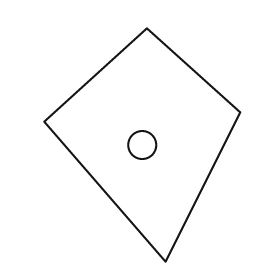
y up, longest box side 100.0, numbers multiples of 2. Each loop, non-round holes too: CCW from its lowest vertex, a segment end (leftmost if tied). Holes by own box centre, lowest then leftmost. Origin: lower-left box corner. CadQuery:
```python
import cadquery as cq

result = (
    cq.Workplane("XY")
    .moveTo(52.0, 0.0)
    .lineTo(84.0, 64.0)
    .lineTo(44.0, 100.0)
    .lineTo(0.0, 60.0)
    .close()
    .moveTo(42.0, 50.0)
    .circle(6.0)
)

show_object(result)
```